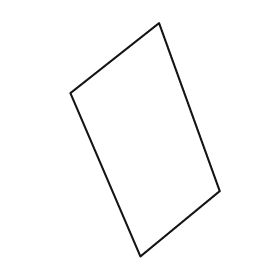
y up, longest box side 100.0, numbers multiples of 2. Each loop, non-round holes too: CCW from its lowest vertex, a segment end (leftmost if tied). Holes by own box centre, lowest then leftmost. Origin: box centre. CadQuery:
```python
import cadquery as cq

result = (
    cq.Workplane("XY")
    .moveTo(-2.0, -50.0)
    .lineTo(32.0, -22.0)
    .lineTo(6.0, 50.0)
    .lineTo(-32.0, 20.0)
    .close()
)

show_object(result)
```